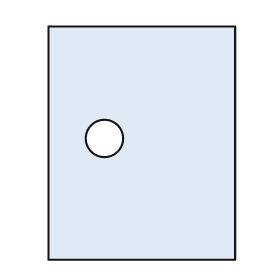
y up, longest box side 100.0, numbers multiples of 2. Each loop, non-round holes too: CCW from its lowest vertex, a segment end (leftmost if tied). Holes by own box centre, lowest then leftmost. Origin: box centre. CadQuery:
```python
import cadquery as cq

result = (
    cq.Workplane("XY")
    .moveTo(-40.0, -50.0)
    .lineTo(40.0, -50.0)
    .lineTo(40.0, 50.0)
    .lineTo(-40.0, 50.0)
    .close()
    .moveTo(-16.0, 2.0)
    .circle(8.0)
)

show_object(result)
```